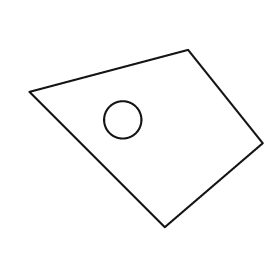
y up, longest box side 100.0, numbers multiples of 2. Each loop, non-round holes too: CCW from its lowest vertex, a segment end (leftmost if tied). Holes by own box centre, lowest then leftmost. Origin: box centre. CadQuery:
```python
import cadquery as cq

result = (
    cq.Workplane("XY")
    .moveTo(8.0, -38.0)
    .lineTo(50.0, -2.0)
    .lineTo(18.0, 38.0)
    .lineTo(-50.0, 20.0)
    .close()
    .moveTo(-10.0, 8.0)
    .circle(8.0)
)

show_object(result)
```